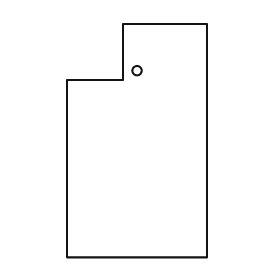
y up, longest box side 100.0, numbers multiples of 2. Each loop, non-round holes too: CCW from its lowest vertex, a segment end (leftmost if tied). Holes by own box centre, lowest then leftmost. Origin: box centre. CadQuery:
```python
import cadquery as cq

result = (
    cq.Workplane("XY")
    .moveTo(-30.0, -50.0)
    .lineTo(30.0, -50.0)
    .lineTo(30.0, 50.0)
    .lineTo(-6.0, 50.0)
    .lineTo(-6.0, 26.0)
    .lineTo(-30.0, 26.0)
    .close()
    .moveTo(0.0, 30.0)
    .circle(2.0)
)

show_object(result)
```